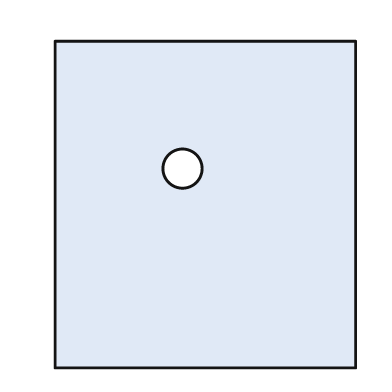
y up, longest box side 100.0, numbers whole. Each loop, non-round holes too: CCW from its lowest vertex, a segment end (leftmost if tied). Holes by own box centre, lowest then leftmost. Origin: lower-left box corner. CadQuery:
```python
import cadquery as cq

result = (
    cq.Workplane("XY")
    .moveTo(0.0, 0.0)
    .lineTo(92.0, 0.0)
    .lineTo(92.0, 100.0)
    .lineTo(0.0, 100.0)
    .close()
    .moveTo(39.0, 61.0)
    .circle(6.0)
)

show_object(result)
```